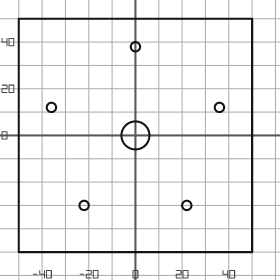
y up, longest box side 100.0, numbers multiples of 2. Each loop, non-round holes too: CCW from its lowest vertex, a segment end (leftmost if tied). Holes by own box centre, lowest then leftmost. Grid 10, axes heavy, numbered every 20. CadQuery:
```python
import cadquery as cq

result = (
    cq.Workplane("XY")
    .moveTo(-50.0, -50.0)
    .lineTo(50.0, -50.0)
    .lineTo(50.0, 50.0)
    .lineTo(-50.0, 50.0)
    .close()
    .moveTo(-22.0, -30.0)
    .circle(2.0)
    .moveTo(22.0, -30.0)
    .circle(2.0)
    .moveTo(0.0, 0.0)
    .circle(6.0)
    .moveTo(-36.0, 12.0)
    .circle(2.0)
    .moveTo(36.0, 12.0)
    .circle(2.0)
    .moveTo(0.0, 38.0)
    .circle(2.0)
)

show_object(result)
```